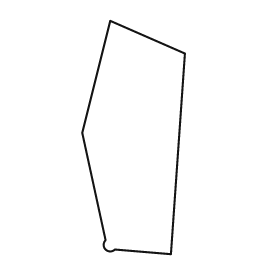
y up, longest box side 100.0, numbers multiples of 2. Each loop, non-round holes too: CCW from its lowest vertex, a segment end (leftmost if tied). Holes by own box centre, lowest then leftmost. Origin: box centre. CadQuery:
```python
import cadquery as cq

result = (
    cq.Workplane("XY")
    .moveTo(16.0, -50.0)
    .lineTo(22.0, 36.0)
    .lineTo(-10.0, 50.0)
    .lineTo(-22.0, 2.0)
    .lineTo(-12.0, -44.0)
    .threePointArc((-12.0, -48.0), (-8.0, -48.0))
    .close()
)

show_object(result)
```